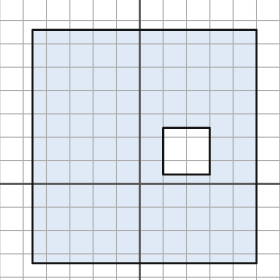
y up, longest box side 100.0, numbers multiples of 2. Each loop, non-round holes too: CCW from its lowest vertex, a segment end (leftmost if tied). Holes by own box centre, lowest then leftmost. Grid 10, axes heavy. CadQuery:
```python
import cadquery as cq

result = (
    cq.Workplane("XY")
    .moveTo(-46.0, -34.0)
    .lineTo(50.0, -34.0)
    .lineTo(50.0, 66.0)
    .lineTo(-46.0, 66.0)
    .close()
    .moveTo(10.0, 4.0)
    .lineTo(30.0, 4.0)
    .lineTo(30.0, 24.0)
    .lineTo(10.0, 24.0)
    .close()
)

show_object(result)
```